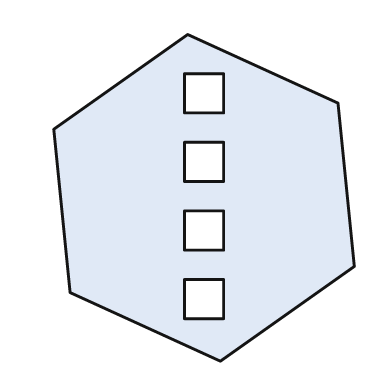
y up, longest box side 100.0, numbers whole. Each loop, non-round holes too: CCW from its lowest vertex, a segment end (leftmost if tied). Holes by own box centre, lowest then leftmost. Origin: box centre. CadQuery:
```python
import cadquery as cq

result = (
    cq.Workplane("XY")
    .moveTo(5.0, -50.0)
    .lineTo(46.0, -21.0)
    .lineTo(41.0, 29.0)
    .lineTo(-5.0, 50.0)
    .lineTo(-46.0, 21.0)
    .lineTo(-41.0, -29.0)
    .close()
    .moveTo(-6.0, -37.0)
    .lineTo(6.0, -37.0)
    .lineTo(6.0, -25.0)
    .lineTo(-6.0, -25.0)
    .close()
    .moveTo(-6.0, -16.0)
    .lineTo(6.0, -16.0)
    .lineTo(6.0, -4.0)
    .lineTo(-6.0, -4.0)
    .close()
    .moveTo(-6.0, 5.0)
    .lineTo(6.0, 5.0)
    .lineTo(6.0, 17.0)
    .lineTo(-6.0, 17.0)
    .close()
    .moveTo(-6.0, 26.0)
    .lineTo(6.0, 26.0)
    .lineTo(6.0, 38.0)
    .lineTo(-6.0, 38.0)
    .close()
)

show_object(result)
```